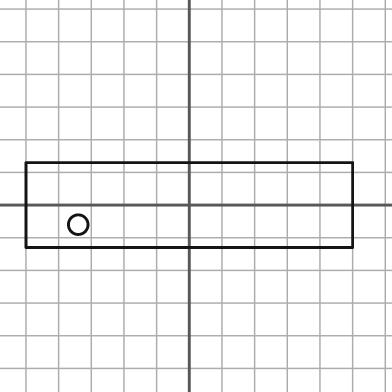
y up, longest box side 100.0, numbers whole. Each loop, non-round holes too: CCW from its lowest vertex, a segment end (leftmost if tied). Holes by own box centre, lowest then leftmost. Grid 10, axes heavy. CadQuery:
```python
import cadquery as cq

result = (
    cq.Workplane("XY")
    .moveTo(-50.0, -13.0)
    .lineTo(50.0, -13.0)
    .lineTo(50.0, 13.0)
    .lineTo(-50.0, 13.0)
    .close()
    .moveTo(-34.0, -6.0)
    .circle(3.0)
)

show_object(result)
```